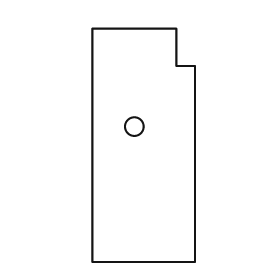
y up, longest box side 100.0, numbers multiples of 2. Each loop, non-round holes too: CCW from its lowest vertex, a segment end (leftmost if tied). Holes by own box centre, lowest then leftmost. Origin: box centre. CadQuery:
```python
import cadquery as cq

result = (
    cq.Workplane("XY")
    .moveTo(-22.0, -50.0)
    .lineTo(22.0, -50.0)
    .lineTo(22.0, 34.0)
    .lineTo(14.0, 34.0)
    .lineTo(14.0, 50.0)
    .lineTo(-22.0, 50.0)
    .close()
    .moveTo(-4.0, 8.0)
    .circle(4.0)
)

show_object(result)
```